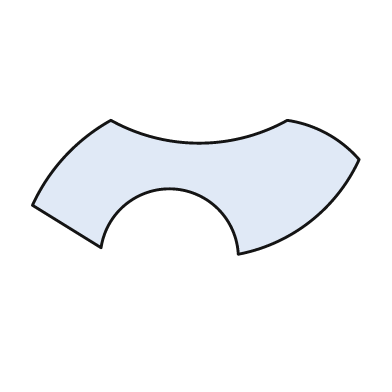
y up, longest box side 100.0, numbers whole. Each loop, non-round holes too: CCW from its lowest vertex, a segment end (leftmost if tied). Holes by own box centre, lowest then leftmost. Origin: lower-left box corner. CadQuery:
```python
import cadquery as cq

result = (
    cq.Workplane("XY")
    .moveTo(63.0, 0.0)
    .threePointArc((85.0, 10.0), (100.0, 29.0))
    .threePointArc((90.0, 37.0), (78.0, 41.0))
    .threePointArc((51.0, 34.0), (24.0, 41.0))
    .threePointArc((10.0, 30.0), (0.0, 15.0))
    .lineTo(21.0, 2.0)
    .threePointArc((43.0, 20.0), (63.0, 0.0))
    .close()
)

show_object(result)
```